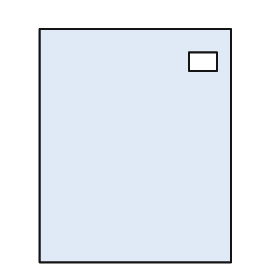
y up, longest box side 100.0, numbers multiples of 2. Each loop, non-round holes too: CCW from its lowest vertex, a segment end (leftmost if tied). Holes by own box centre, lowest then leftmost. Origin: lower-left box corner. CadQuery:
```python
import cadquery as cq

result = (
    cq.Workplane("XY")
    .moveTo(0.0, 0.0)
    .lineTo(82.0, 0.0)
    .lineTo(82.0, 100.0)
    .lineTo(0.0, 100.0)
    .close()
    .moveTo(64.0, 82.0)
    .lineTo(76.0, 82.0)
    .lineTo(76.0, 90.0)
    .lineTo(64.0, 90.0)
    .close()
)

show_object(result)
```